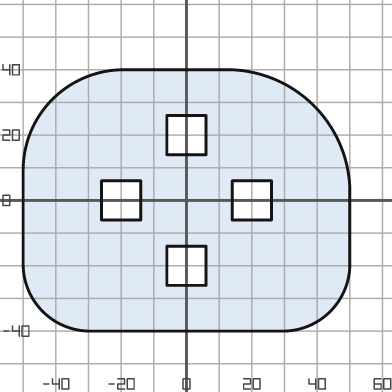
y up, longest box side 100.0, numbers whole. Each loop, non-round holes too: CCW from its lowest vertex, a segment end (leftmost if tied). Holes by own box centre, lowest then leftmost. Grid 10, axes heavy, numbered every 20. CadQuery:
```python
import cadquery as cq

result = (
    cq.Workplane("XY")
    .moveTo(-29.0, -40.0)
    .lineTo(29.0, -40.0)
    .threePointArc((44.0, -34.0), (50.0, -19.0))
    .lineTo(50.0, 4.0)
    .threePointArc((39.0, 29.0), (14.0, 40.0))
    .lineTo(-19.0, 40.0)
    .threePointArc((-41.0, 31.0), (-50.0, 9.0))
    .lineTo(-50.0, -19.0)
    .threePointArc((-44.0, -34.0), (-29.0, -40.0))
    .close()
    .moveTo(-6.0, -26.0)
    .lineTo(6.0, -26.0)
    .lineTo(6.0, -14.0)
    .lineTo(-6.0, -14.0)
    .close()
    .moveTo(-26.0, -6.0)
    .lineTo(-14.0, -6.0)
    .lineTo(-14.0, 6.0)
    .lineTo(-26.0, 6.0)
    .close()
    .moveTo(14.0, -6.0)
    .lineTo(26.0, -6.0)
    .lineTo(26.0, 6.0)
    .lineTo(14.0, 6.0)
    .close()
    .moveTo(-6.0, 14.0)
    .lineTo(6.0, 14.0)
    .lineTo(6.0, 26.0)
    .lineTo(-6.0, 26.0)
    .close()
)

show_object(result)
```